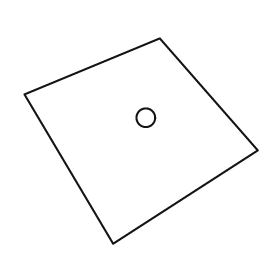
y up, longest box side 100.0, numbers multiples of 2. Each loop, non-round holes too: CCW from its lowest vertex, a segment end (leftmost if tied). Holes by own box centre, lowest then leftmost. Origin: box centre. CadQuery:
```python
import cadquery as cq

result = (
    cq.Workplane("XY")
    .moveTo(-12.0, -44.0)
    .lineTo(50.0, -4.0)
    .lineTo(8.0, 44.0)
    .lineTo(-50.0, 20.0)
    .close()
    .moveTo(2.0, 10.0)
    .circle(4.0)
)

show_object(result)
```